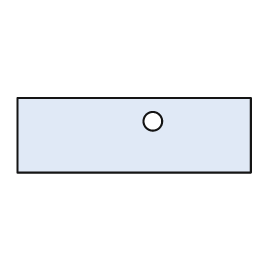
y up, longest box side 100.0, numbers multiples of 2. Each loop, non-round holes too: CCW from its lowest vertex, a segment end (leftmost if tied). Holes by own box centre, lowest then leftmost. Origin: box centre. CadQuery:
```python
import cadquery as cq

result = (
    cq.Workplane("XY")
    .moveTo(-50.0, -16.0)
    .lineTo(50.0, -16.0)
    .lineTo(50.0, 16.0)
    .lineTo(-50.0, 16.0)
    .close()
    .moveTo(8.0, 6.0)
    .circle(4.0)
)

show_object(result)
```